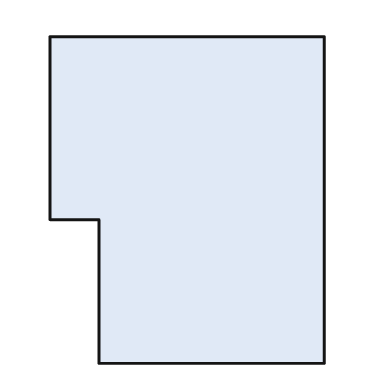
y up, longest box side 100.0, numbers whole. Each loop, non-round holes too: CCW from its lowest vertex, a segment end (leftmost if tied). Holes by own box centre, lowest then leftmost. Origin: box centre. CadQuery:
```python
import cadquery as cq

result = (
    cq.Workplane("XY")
    .moveTo(-27.0, -50.0)
    .lineTo(42.0, -50.0)
    .lineTo(42.0, 50.0)
    .lineTo(-42.0, 50.0)
    .lineTo(-42.0, -6.0)
    .lineTo(-27.0, -6.0)
    .close()
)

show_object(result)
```